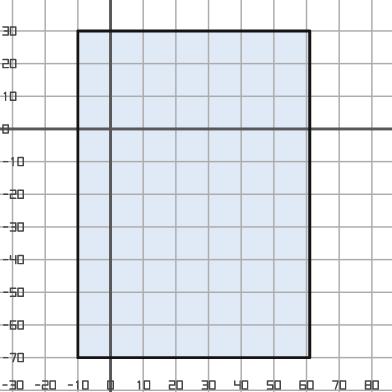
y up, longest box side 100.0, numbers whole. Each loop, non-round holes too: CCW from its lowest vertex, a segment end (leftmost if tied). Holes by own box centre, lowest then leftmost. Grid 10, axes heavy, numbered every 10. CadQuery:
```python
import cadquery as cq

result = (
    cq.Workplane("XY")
    .moveTo(-10.0, -70.0)
    .lineTo(61.0, -70.0)
    .lineTo(61.0, 30.0)
    .lineTo(-10.0, 30.0)
    .close()
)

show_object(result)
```